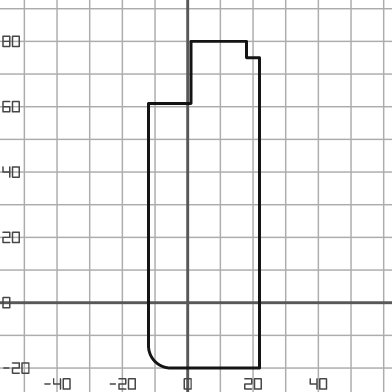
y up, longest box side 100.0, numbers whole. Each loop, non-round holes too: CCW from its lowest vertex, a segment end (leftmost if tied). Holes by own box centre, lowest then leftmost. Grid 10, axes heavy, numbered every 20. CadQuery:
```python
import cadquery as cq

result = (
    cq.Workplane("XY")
    .moveTo(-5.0, -20.0)
    .lineTo(22.0, -20.0)
    .lineTo(22.0, 75.0)
    .lineTo(18.0, 75.0)
    .lineTo(18.0, 80.0)
    .lineTo(1.0, 80.0)
    .lineTo(1.0, 61.0)
    .lineTo(-12.0, 61.0)
    .lineTo(-12.0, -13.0)
    .threePointArc((-10.0, -18.0), (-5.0, -20.0))
    .close()
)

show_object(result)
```